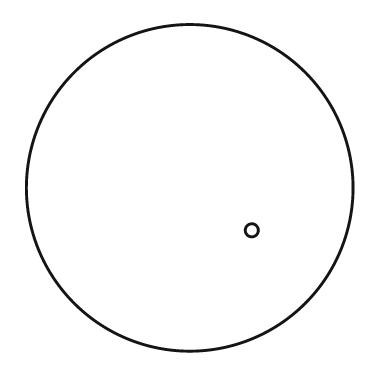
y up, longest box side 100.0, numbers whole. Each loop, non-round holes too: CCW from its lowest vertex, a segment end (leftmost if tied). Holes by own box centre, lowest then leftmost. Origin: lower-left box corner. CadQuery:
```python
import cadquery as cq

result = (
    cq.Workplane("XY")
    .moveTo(50.0, 50.0)
    .circle(50.0)
    .moveTo(69.0, 37.0)
    .circle(2.0)
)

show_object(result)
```